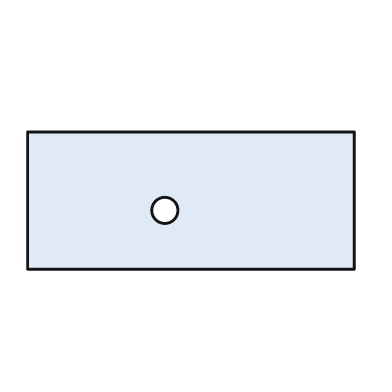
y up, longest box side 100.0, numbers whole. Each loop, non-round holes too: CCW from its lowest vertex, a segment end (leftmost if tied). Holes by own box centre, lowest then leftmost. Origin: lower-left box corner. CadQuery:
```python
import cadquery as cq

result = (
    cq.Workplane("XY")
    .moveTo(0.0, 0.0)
    .lineTo(100.0, 0.0)
    .lineTo(100.0, 42.0)
    .lineTo(0.0, 42.0)
    .close()
    .moveTo(42.0, 18.0)
    .circle(4.0)
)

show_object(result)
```